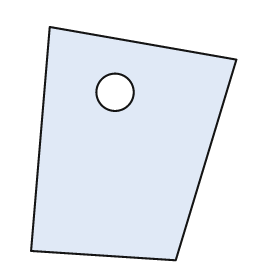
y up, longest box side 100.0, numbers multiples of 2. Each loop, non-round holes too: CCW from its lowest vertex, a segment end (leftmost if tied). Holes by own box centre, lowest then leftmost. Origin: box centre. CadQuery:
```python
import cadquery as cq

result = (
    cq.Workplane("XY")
    .moveTo(18.0, -50.0)
    .lineTo(44.0, 36.0)
    .lineTo(-36.0, 50.0)
    .lineTo(-44.0, -46.0)
    .close()
    .moveTo(-8.0, 22.0)
    .circle(8.0)
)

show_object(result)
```